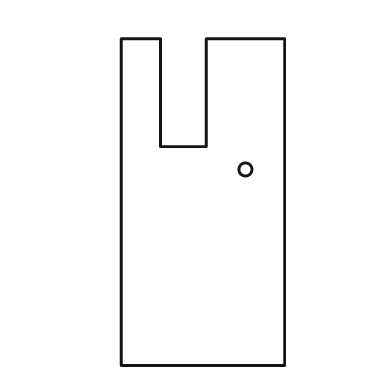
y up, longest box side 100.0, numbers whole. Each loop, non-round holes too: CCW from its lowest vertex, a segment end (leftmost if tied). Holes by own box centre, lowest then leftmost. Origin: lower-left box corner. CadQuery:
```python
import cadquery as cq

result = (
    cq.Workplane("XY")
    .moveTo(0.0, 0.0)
    .lineTo(50.0, 0.0)
    .lineTo(50.0, 100.0)
    .lineTo(26.0, 100.0)
    .lineTo(26.0, 67.0)
    .lineTo(12.0, 67.0)
    .lineTo(12.0, 100.0)
    .lineTo(0.0, 100.0)
    .close()
    .moveTo(38.0, 60.0)
    .circle(2.0)
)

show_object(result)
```